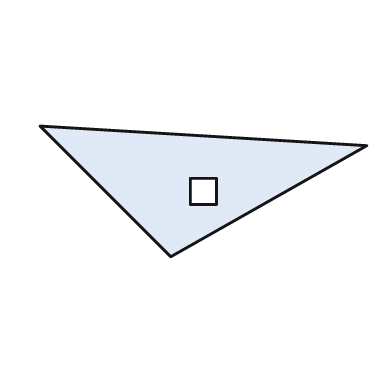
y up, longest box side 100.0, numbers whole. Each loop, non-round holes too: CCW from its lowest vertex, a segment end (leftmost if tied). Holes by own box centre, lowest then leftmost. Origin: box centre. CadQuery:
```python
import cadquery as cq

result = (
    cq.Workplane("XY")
    .moveTo(-10.0, -20.0)
    .lineTo(50.0, 14.0)
    .lineTo(-50.0, 20.0)
    .close()
    .moveTo(-4.0, -4.0)
    .lineTo(4.0, -4.0)
    .lineTo(4.0, 4.0)
    .lineTo(-4.0, 4.0)
    .close()
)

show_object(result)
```